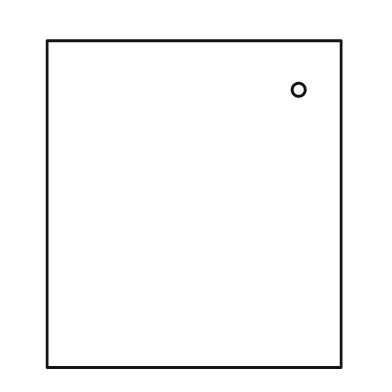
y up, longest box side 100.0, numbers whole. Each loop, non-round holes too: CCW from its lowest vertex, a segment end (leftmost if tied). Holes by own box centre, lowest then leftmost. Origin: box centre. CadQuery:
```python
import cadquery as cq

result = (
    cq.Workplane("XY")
    .moveTo(-45.0, -50.0)
    .lineTo(45.0, -50.0)
    .lineTo(45.0, 50.0)
    .lineTo(-45.0, 50.0)
    .close()
    .moveTo(32.0, 35.0)
    .circle(2.0)
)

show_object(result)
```